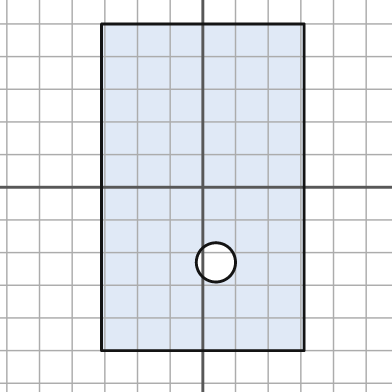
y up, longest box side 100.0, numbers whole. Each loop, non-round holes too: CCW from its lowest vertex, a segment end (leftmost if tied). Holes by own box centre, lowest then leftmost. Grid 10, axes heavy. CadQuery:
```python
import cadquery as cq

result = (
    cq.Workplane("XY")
    .moveTo(-31.0, -50.0)
    .lineTo(31.0, -50.0)
    .lineTo(31.0, 50.0)
    .lineTo(-31.0, 50.0)
    .close()
    .moveTo(4.0, -23.0)
    .circle(6.0)
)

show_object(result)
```